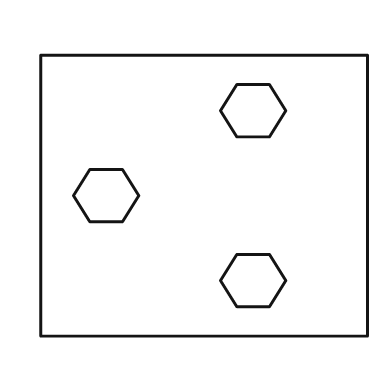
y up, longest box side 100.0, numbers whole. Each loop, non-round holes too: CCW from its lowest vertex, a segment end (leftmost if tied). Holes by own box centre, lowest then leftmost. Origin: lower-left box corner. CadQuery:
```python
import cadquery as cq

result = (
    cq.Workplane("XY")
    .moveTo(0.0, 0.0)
    .lineTo(100.0, 0.0)
    .lineTo(100.0, 86.0)
    .lineTo(0.0, 86.0)
    .close()
    .moveTo(60.0, 9.0)
    .lineTo(70.0, 9.0)
    .lineTo(75.0, 17.0)
    .lineTo(70.0, 25.0)
    .lineTo(60.0, 25.0)
    .lineTo(55.0, 17.0)
    .close()
    .moveTo(15.0, 35.0)
    .lineTo(25.0, 35.0)
    .lineTo(30.0, 43.0)
    .lineTo(25.0, 51.0)
    .lineTo(15.0, 51.0)
    .lineTo(10.0, 43.0)
    .close()
    .moveTo(60.0, 61.0)
    .lineTo(70.0, 61.0)
    .lineTo(75.0, 69.0)
    .lineTo(70.0, 77.0)
    .lineTo(60.0, 77.0)
    .lineTo(55.0, 69.0)
    .close()
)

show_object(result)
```